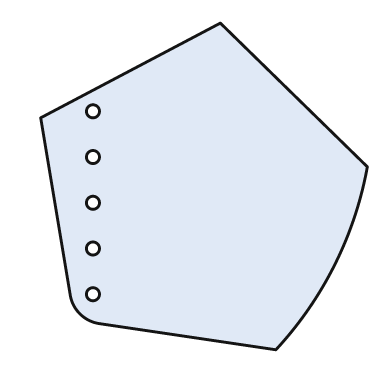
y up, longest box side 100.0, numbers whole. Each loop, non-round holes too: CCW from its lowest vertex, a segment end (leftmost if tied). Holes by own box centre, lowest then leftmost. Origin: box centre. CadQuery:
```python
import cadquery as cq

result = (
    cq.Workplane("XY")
    .moveTo(22.0, -50.0)
    .threePointArc((40.0, -24.0), (50.0, 6.0))
    .lineTo(5.0, 50.0)
    .lineTo(-50.0, 21.0)
    .lineTo(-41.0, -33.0)
    .threePointArc((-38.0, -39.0), (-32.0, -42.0))
    .close()
    .moveTo(-34.0, -33.0)
    .circle(2.0)
    .moveTo(-34.0, -19.0)
    .circle(2.0)
    .moveTo(-34.0, -5.0)
    .circle(2.0)
    .moveTo(-34.0, 9.0)
    .circle(2.0)
    .moveTo(-34.0, 23.0)
    .circle(2.0)
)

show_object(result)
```